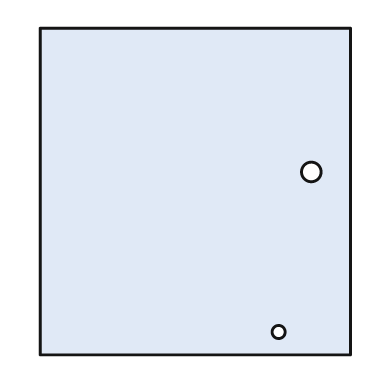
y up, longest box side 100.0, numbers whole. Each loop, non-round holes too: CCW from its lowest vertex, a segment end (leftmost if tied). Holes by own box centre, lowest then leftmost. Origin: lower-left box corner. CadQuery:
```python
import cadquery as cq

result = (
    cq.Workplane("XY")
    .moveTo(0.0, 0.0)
    .lineTo(95.0, 0.0)
    .lineTo(95.0, 100.0)
    .lineTo(0.0, 100.0)
    .close()
    .moveTo(73.0, 7.0)
    .circle(2.0)
    .moveTo(83.0, 56.0)
    .circle(3.0)
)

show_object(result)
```